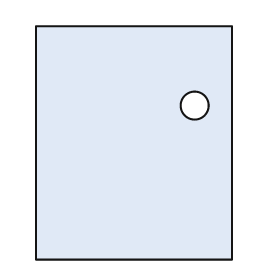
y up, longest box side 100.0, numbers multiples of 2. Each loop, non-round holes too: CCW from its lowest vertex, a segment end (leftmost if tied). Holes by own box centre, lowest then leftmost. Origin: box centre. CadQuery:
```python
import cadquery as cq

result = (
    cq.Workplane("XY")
    .moveTo(-42.0, -50.0)
    .lineTo(42.0, -50.0)
    .lineTo(42.0, 50.0)
    .lineTo(-42.0, 50.0)
    .close()
    .moveTo(26.0, 16.0)
    .circle(6.0)
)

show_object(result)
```